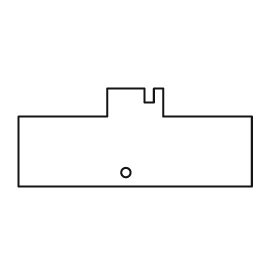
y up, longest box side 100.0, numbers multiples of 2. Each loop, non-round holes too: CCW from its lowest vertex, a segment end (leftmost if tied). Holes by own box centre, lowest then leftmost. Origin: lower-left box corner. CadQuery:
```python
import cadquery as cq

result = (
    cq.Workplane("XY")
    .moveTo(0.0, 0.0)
    .lineTo(100.0, 0.0)
    .lineTo(100.0, 30.0)
    .lineTo(62.0, 30.0)
    .lineTo(62.0, 42.0)
    .lineTo(58.0, 42.0)
    .lineTo(58.0, 36.0)
    .lineTo(54.0, 36.0)
    .lineTo(54.0, 42.0)
    .lineTo(38.0, 42.0)
    .lineTo(38.0, 30.0)
    .lineTo(0.0, 30.0)
    .close()
    .moveTo(46.0, 6.0)
    .circle(2.0)
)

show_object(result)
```